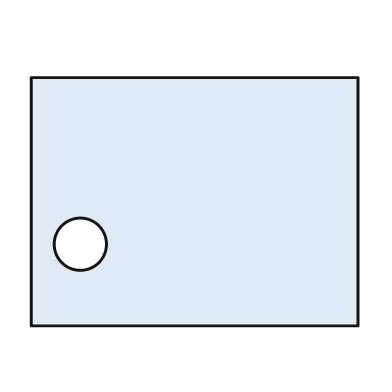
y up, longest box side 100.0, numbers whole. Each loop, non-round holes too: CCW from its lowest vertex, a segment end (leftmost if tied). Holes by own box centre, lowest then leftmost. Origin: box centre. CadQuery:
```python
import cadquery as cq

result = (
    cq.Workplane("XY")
    .moveTo(-50.0, -38.0)
    .lineTo(50.0, -38.0)
    .lineTo(50.0, 38.0)
    .lineTo(-50.0, 38.0)
    .close()
    .moveTo(-35.0, -13.0)
    .circle(8.0)
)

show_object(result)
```